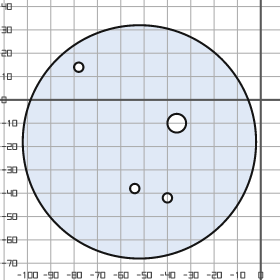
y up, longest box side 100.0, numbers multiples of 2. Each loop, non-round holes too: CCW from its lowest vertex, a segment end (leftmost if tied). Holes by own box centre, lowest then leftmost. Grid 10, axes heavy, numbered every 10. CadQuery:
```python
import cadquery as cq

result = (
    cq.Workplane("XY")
    .moveTo(-52.0, -18.0)
    .circle(50.0)
    .moveTo(-40.0, -42.0)
    .circle(2.0)
    .moveTo(-54.0, -38.0)
    .circle(2.0)
    .moveTo(-36.0, -10.0)
    .circle(4.0)
    .moveTo(-78.0, 14.0)
    .circle(2.0)
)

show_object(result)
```